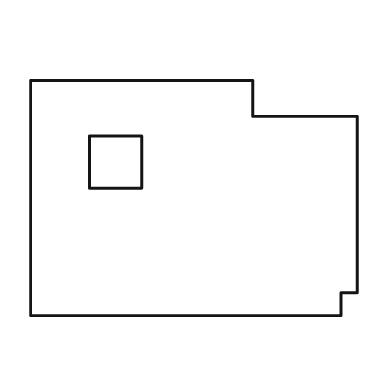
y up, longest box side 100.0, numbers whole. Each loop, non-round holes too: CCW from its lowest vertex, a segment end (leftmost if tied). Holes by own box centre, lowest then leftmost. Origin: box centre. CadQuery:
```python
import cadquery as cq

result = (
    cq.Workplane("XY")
    .moveTo(-50.0, -36.0)
    .lineTo(45.0, -36.0)
    .lineTo(45.0, -29.0)
    .lineTo(50.0, -29.0)
    .lineTo(50.0, 25.0)
    .lineTo(18.0, 25.0)
    .lineTo(18.0, 36.0)
    .lineTo(-50.0, 36.0)
    .close()
    .moveTo(-32.0, 3.0)
    .lineTo(-16.0, 3.0)
    .lineTo(-16.0, 19.0)
    .lineTo(-32.0, 19.0)
    .close()
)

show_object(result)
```